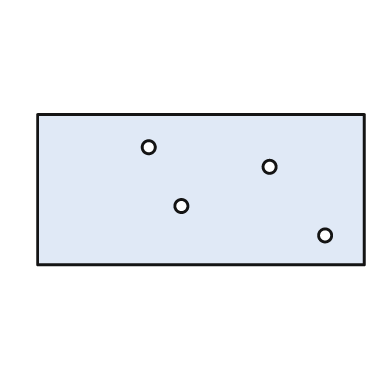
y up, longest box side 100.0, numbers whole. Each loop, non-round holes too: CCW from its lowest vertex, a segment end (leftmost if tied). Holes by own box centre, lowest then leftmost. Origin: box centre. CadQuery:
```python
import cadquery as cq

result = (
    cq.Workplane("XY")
    .moveTo(-50.0, -23.0)
    .lineTo(50.0, -23.0)
    .lineTo(50.0, 23.0)
    .lineTo(-50.0, 23.0)
    .close()
    .moveTo(38.0, -14.0)
    .circle(2.0)
    .moveTo(-6.0, -5.0)
    .circle(2.0)
    .moveTo(21.0, 7.0)
    .circle(2.0)
    .moveTo(-16.0, 13.0)
    .circle(2.0)
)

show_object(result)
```